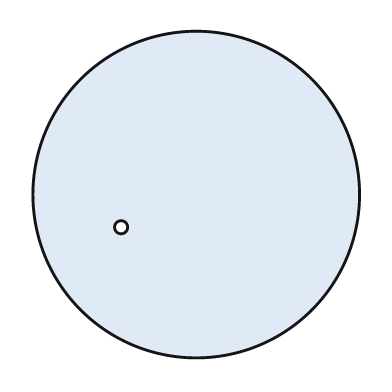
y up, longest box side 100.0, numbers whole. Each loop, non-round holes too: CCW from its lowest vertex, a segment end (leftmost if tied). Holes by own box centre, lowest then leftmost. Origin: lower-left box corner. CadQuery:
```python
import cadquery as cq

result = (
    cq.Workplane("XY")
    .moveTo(50.0, 50.0)
    .circle(50.0)
    .moveTo(27.0, 40.0)
    .circle(2.0)
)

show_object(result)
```